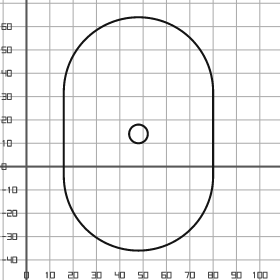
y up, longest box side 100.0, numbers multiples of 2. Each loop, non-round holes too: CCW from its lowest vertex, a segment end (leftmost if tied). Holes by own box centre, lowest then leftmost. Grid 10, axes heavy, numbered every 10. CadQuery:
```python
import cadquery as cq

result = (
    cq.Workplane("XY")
    .moveTo(16.0, -4.0)
    .threePointArc((48.0, -36.0), (80.0, -4.0))
    .lineTo(80.0, 32.0)
    .threePointArc((48.0, 64.0), (16.0, 32.0))
    .close()
    .moveTo(48.0, 14.0)
    .circle(4.0)
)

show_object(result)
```